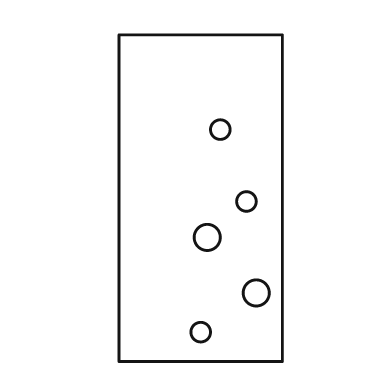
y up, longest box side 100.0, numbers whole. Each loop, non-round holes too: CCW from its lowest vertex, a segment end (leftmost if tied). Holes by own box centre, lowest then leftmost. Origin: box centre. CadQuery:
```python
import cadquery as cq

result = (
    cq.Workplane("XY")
    .moveTo(-25.0, -50.0)
    .lineTo(25.0, -50.0)
    .lineTo(25.0, 50.0)
    .lineTo(-25.0, 50.0)
    .close()
    .moveTo(0.0, -41.0)
    .circle(3.0)
    .moveTo(17.0, -29.0)
    .circle(4.0)
    .moveTo(2.0, -12.0)
    .circle(4.0)
    .moveTo(14.0, -1.0)
    .circle(3.0)
    .moveTo(6.0, 21.0)
    .circle(3.0)
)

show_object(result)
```